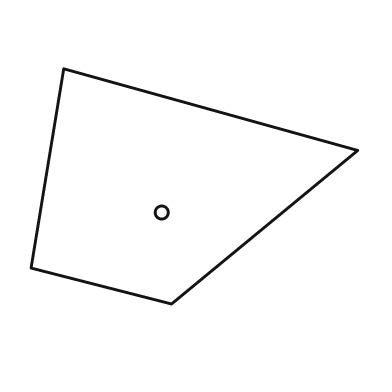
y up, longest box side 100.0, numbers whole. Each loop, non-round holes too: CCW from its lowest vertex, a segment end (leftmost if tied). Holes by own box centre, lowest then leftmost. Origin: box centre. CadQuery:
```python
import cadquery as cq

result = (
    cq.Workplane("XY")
    .moveTo(-7.0, -36.0)
    .lineTo(50.0, 11.0)
    .lineTo(-40.0, 36.0)
    .lineTo(-50.0, -25.0)
    .close()
    .moveTo(-10.0, -8.0)
    .circle(2.0)
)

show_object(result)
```